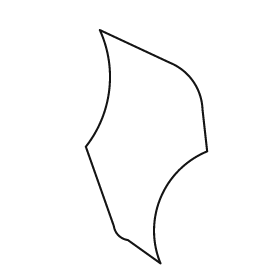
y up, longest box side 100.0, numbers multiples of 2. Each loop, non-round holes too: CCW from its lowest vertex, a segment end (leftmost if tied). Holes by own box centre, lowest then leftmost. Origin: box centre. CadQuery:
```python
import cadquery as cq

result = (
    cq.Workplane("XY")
    .moveTo(6.0, -50.0)
    .threePointArc((6.0, -22.0), (26.0, -2.0))
    .lineTo(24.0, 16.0)
    .threePointArc((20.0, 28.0), (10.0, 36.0))
    .lineTo(-20.0, 50.0)
    .threePointArc((-16.0, 24.0), (-26.0, 0.0))
    .lineTo(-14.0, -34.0)
    .threePointArc((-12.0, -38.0), (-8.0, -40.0))
    .close()
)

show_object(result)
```